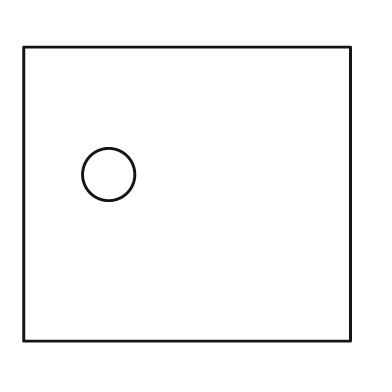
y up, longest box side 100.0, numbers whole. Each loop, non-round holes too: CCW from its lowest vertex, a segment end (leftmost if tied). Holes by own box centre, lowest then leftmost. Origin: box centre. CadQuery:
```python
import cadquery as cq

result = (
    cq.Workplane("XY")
    .moveTo(-50.0, -45.0)
    .lineTo(50.0, -45.0)
    .lineTo(50.0, 45.0)
    .lineTo(-50.0, 45.0)
    .close()
    .moveTo(-24.0, 6.0)
    .circle(8.0)
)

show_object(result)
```